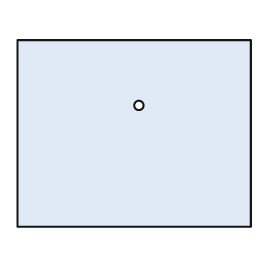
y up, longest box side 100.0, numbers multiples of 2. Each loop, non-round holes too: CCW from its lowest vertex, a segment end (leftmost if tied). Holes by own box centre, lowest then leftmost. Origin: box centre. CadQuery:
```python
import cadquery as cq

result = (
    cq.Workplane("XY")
    .moveTo(-50.0, -40.0)
    .lineTo(50.0, -40.0)
    .lineTo(50.0, 40.0)
    .lineTo(-50.0, 40.0)
    .close()
    .moveTo(2.0, 12.0)
    .circle(2.0)
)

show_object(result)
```